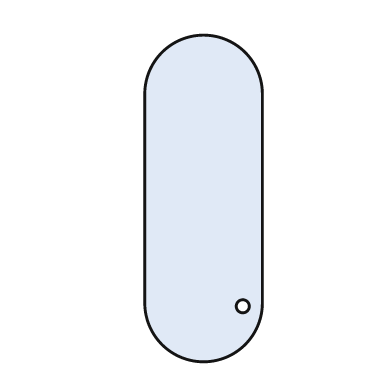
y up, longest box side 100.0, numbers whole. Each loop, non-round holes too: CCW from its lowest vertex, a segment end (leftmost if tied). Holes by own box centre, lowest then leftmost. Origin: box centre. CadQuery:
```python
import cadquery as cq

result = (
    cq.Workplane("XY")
    .moveTo(-18.0, -32.0)
    .threePointArc((0.0, -50.0), (18.0, -32.0))
    .lineTo(18.0, 32.0)
    .threePointArc((0.0, 50.0), (-18.0, 32.0))
    .close()
    .moveTo(12.0, -33.0)
    .circle(2.0)
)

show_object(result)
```